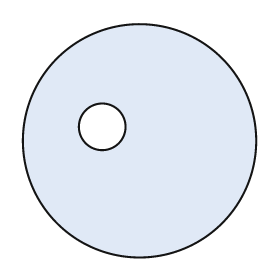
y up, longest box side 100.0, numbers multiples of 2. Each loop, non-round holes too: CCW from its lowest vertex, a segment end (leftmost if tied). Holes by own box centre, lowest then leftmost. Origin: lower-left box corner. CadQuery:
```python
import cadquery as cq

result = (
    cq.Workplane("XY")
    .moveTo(50.0, 50.0)
    .circle(50.0)
    .moveTo(34.0, 56.0)
    .circle(10.0)
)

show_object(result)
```